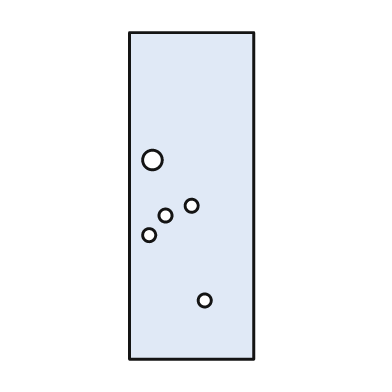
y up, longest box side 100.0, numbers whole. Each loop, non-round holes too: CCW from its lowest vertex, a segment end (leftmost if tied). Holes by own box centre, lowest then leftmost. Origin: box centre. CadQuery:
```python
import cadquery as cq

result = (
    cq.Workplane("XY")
    .moveTo(-19.0, -50.0)
    .lineTo(19.0, -50.0)
    .lineTo(19.0, 50.0)
    .lineTo(-19.0, 50.0)
    .close()
    .moveTo(4.0, -32.0)
    .circle(2.0)
    .moveTo(-13.0, -12.0)
    .circle(2.0)
    .moveTo(-8.0, -6.0)
    .circle(2.0)
    .moveTo(0.0, -3.0)
    .circle(2.0)
    .moveTo(-12.0, 11.0)
    .circle(3.0)
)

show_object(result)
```